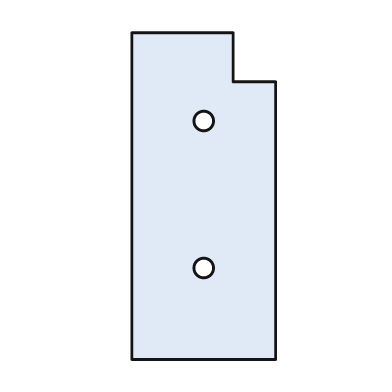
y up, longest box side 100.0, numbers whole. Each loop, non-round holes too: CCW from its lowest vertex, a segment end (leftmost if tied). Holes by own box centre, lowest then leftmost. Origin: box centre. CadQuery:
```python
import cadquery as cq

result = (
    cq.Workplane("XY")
    .moveTo(-22.0, -50.0)
    .lineTo(22.0, -50.0)
    .lineTo(22.0, 35.0)
    .lineTo(9.0, 35.0)
    .lineTo(9.0, 50.0)
    .lineTo(-22.0, 50.0)
    .close()
    .moveTo(0.0, -22.0)
    .circle(3.0)
    .moveTo(0.0, 23.0)
    .circle(3.0)
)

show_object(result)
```